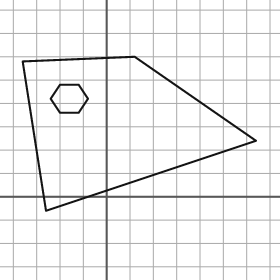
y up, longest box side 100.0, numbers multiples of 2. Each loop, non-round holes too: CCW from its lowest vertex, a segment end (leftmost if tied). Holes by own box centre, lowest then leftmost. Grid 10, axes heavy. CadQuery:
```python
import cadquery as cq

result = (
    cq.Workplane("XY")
    .moveTo(-26.0, -6.0)
    .lineTo(64.0, 24.0)
    .lineTo(12.0, 60.0)
    .lineTo(-36.0, 58.0)
    .close()
    .moveTo(-20.0, 36.0)
    .lineTo(-12.0, 36.0)
    .lineTo(-8.0, 42.0)
    .lineTo(-12.0, 48.0)
    .lineTo(-20.0, 48.0)
    .lineTo(-24.0, 42.0)
    .close()
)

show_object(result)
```